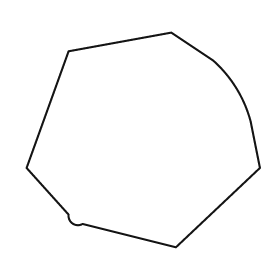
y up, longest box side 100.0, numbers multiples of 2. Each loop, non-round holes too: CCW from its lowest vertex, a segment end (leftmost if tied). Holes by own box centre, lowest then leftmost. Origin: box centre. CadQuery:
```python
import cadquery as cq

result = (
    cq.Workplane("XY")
    .moveTo(14.0, -46.0)
    .lineTo(50.0, -12.0)
    .lineTo(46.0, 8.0)
    .threePointArc((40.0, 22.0), (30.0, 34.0))
    .lineTo(12.0, 46.0)
    .lineTo(-32.0, 38.0)
    .lineTo(-50.0, -12.0)
    .lineTo(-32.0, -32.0)
    .threePointArc((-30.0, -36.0), (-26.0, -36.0))
    .close()
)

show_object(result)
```